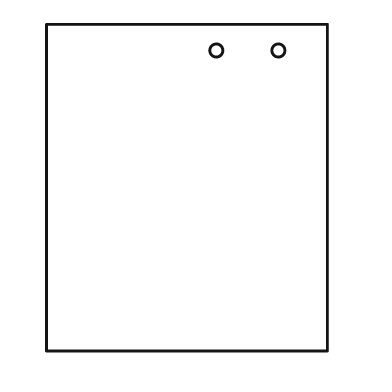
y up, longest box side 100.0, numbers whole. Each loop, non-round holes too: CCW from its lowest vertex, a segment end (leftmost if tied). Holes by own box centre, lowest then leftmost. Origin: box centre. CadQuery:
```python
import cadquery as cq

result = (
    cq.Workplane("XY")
    .moveTo(-43.0, -50.0)
    .lineTo(43.0, -50.0)
    .lineTo(43.0, 50.0)
    .lineTo(-43.0, 50.0)
    .close()
    .moveTo(9.0, 42.0)
    .circle(2.0)
    .moveTo(28.0, 42.0)
    .circle(2.0)
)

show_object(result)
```